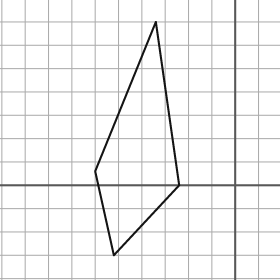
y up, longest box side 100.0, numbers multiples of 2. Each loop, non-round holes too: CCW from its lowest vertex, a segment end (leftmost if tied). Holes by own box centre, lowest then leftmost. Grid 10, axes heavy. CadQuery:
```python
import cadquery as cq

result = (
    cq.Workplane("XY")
    .moveTo(-52.0, -30.0)
    .lineTo(-24.0, 0.0)
    .lineTo(-34.0, 70.0)
    .lineTo(-60.0, 6.0)
    .close()
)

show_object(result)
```